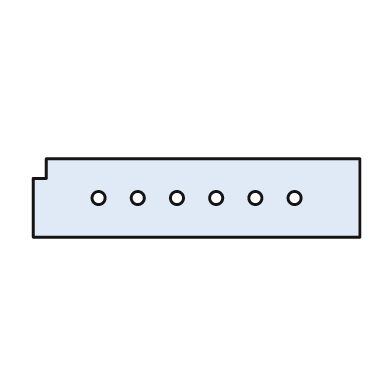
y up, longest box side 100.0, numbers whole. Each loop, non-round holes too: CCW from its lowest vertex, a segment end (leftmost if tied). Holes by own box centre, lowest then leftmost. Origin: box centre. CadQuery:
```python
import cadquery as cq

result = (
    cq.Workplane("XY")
    .moveTo(-50.0, -12.0)
    .lineTo(50.0, -12.0)
    .lineTo(50.0, 12.0)
    .lineTo(-46.0, 12.0)
    .lineTo(-46.0, 6.0)
    .lineTo(-50.0, 6.0)
    .close()
    .moveTo(-30.0, 0.0)
    .circle(2.0)
    .moveTo(-18.0, 0.0)
    .circle(2.0)
    .moveTo(-6.0, 0.0)
    .circle(2.0)
    .moveTo(6.0, 0.0)
    .circle(2.0)
    .moveTo(18.0, 0.0)
    .circle(2.0)
    .moveTo(30.0, 0.0)
    .circle(2.0)
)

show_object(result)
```